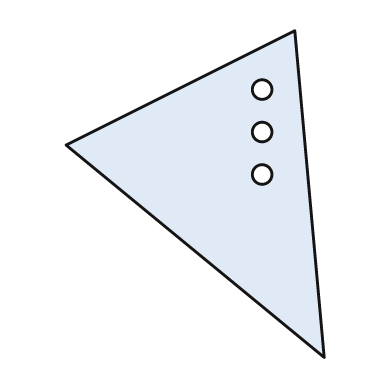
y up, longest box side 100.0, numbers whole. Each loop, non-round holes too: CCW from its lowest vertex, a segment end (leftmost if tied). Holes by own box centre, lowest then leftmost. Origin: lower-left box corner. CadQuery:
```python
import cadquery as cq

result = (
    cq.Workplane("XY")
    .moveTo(79.0, 0.0)
    .lineTo(70.0, 100.0)
    .lineTo(0.0, 65.0)
    .close()
    .moveTo(60.0, 56.0)
    .circle(3.0)
    .moveTo(60.0, 69.0)
    .circle(3.0)
    .moveTo(60.0, 82.0)
    .circle(3.0)
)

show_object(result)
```